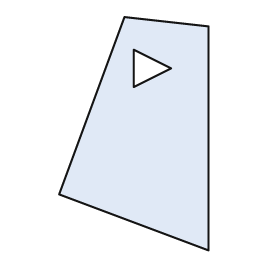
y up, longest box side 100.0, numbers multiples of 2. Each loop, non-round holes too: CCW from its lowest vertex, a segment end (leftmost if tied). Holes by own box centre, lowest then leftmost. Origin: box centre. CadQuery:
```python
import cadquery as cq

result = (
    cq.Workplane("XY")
    .moveTo(32.0, -50.0)
    .lineTo(32.0, 46.0)
    .lineTo(-4.0, 50.0)
    .lineTo(-32.0, -26.0)
    .close()
    .moveTo(0.0, 20.0)
    .lineTo(16.0, 28.0)
    .lineTo(0.0, 36.0)
    .close()
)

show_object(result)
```